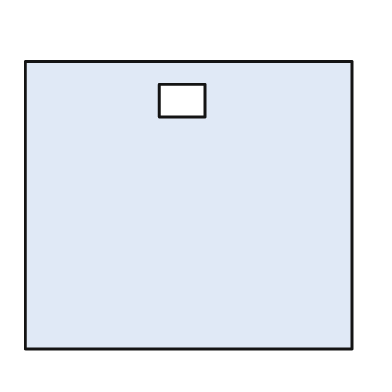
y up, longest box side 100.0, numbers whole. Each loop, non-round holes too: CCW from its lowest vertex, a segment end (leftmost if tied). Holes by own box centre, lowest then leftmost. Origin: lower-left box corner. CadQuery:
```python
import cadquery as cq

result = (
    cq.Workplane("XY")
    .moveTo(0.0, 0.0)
    .lineTo(100.0, 0.0)
    .lineTo(100.0, 88.0)
    .lineTo(0.0, 88.0)
    .close()
    .moveTo(41.0, 71.0)
    .lineTo(55.0, 71.0)
    .lineTo(55.0, 81.0)
    .lineTo(41.0, 81.0)
    .close()
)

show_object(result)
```